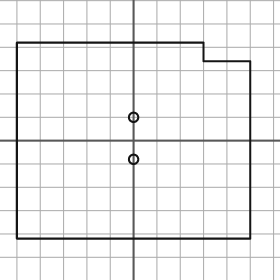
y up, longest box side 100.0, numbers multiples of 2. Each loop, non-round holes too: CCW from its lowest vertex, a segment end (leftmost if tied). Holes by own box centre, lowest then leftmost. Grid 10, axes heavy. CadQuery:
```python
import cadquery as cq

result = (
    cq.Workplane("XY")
    .moveTo(-50.0, -42.0)
    .lineTo(50.0, -42.0)
    .lineTo(50.0, 34.0)
    .lineTo(30.0, 34.0)
    .lineTo(30.0, 42.0)
    .lineTo(-50.0, 42.0)
    .close()
    .moveTo(0.0, -8.0)
    .circle(2.0)
    .moveTo(0.0, 10.0)
    .circle(2.0)
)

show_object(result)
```